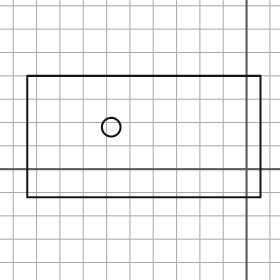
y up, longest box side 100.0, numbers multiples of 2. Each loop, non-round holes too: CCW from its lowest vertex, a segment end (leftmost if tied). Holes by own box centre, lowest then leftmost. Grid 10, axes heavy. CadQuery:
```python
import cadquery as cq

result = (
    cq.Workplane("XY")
    .moveTo(-94.0, -12.0)
    .lineTo(6.0, -12.0)
    .lineTo(6.0, 40.0)
    .lineTo(-94.0, 40.0)
    .close()
    .moveTo(-58.0, 18.0)
    .circle(4.0)
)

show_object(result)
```